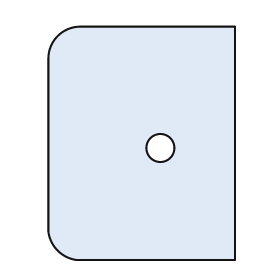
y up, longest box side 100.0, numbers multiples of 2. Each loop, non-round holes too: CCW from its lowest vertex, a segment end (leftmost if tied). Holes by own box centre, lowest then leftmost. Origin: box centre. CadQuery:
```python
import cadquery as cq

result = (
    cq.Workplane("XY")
    .moveTo(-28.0, -50.0)
    .lineTo(40.0, -50.0)
    .lineTo(40.0, 50.0)
    .lineTo(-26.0, 50.0)
    .threePointArc((-36.0, 46.0), (-40.0, 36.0))
    .lineTo(-40.0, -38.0)
    .threePointArc((-36.0, -46.0), (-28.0, -50.0))
    .close()
    .moveTo(8.0, -2.0)
    .circle(6.0)
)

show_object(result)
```